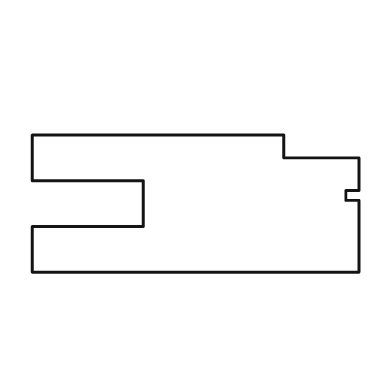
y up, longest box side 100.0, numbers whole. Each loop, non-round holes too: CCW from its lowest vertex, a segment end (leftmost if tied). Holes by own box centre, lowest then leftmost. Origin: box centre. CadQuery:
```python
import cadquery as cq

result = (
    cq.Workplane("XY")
    .moveTo(-50.0, -21.0)
    .lineTo(50.0, -21.0)
    .lineTo(50.0, 1.0)
    .lineTo(46.0, 1.0)
    .lineTo(46.0, 4.0)
    .lineTo(50.0, 4.0)
    .lineTo(50.0, 14.0)
    .lineTo(27.0, 14.0)
    .lineTo(27.0, 21.0)
    .lineTo(-50.0, 21.0)
    .lineTo(-50.0, 7.0)
    .lineTo(-16.0, 7.0)
    .lineTo(-16.0, -7.0)
    .lineTo(-50.0, -7.0)
    .close()
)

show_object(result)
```